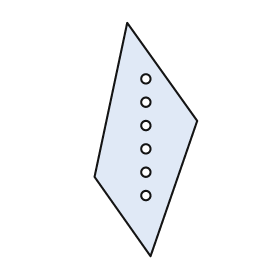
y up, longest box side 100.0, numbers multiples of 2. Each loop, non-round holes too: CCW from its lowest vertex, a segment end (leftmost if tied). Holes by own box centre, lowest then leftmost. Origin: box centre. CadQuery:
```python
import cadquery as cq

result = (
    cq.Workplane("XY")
    .moveTo(2.0, -50.0)
    .lineTo(22.0, 8.0)
    .lineTo(-8.0, 50.0)
    .lineTo(-22.0, -16.0)
    .close()
    .moveTo(0.0, -24.0)
    .circle(2.0)
    .moveTo(0.0, -14.0)
    .circle(2.0)
    .moveTo(0.0, -4.0)
    .circle(2.0)
    .moveTo(0.0, 6.0)
    .circle(2.0)
    .moveTo(0.0, 16.0)
    .circle(2.0)
    .moveTo(0.0, 26.0)
    .circle(2.0)
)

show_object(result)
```